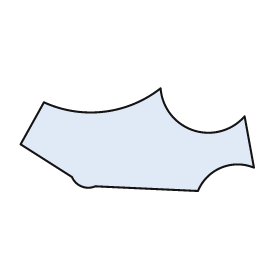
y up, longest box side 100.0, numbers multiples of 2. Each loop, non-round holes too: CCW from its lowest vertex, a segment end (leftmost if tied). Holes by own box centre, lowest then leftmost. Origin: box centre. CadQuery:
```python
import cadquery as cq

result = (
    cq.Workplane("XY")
    .moveTo(26.0, -22.0)
    .threePointArc((36.0, -12.0), (50.0, -12.0))
    .lineTo(46.0, 10.0)
    .threePointArc((24.0, 4.0), (10.0, 22.0))
    .threePointArc((-14.0, 12.0), (-40.0, 16.0))
    .lineTo(-50.0, -2.0)
    .lineTo(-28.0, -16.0)
    .threePointArc((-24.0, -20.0), (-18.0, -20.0))
    .close()
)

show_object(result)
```